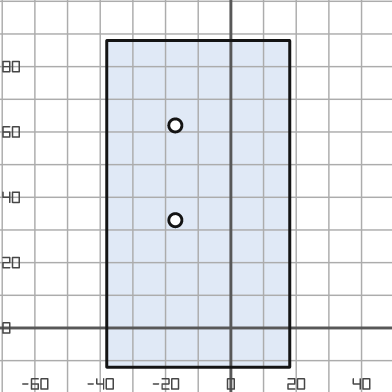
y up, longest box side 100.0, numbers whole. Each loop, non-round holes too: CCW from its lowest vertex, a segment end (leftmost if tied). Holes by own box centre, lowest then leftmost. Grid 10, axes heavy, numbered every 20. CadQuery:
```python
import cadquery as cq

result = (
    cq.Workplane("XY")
    .moveTo(-38.0, -12.0)
    .lineTo(18.0, -12.0)
    .lineTo(18.0, 88.0)
    .lineTo(-38.0, 88.0)
    .close()
    .moveTo(-17.0, 33.0)
    .circle(2.0)
    .moveTo(-17.0, 62.0)
    .circle(2.0)
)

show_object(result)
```